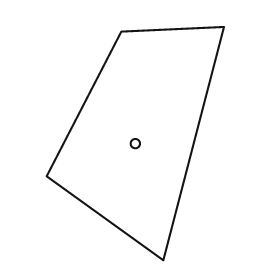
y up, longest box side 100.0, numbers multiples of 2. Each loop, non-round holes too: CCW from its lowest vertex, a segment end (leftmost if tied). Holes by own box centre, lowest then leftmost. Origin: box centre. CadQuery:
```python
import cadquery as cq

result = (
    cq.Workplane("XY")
    .moveTo(12.0, -50.0)
    .lineTo(38.0, 50.0)
    .lineTo(-6.0, 48.0)
    .lineTo(-38.0, -14.0)
    .close()
    .moveTo(0.0, 0.0)
    .circle(2.0)
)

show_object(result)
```